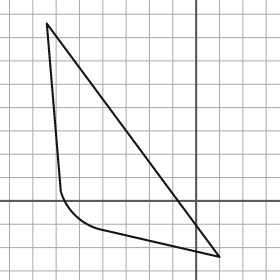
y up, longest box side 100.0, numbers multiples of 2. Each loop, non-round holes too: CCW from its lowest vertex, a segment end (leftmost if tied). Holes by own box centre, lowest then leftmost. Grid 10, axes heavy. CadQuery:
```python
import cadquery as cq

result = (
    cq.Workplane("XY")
    .moveTo(10.0, -24.0)
    .lineTo(-64.0, 76.0)
    .lineTo(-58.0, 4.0)
    .threePointArc((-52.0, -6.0), (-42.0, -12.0))
    .close()
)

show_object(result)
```